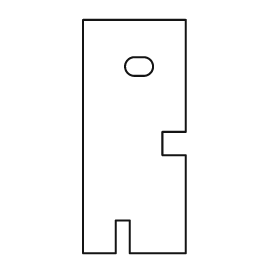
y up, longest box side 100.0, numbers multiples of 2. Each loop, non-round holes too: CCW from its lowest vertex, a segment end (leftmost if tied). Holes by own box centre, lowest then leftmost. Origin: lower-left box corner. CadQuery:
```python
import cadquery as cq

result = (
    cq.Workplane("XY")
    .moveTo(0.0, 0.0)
    .lineTo(14.0, 0.0)
    .lineTo(14.0, 14.0)
    .lineTo(20.0, 14.0)
    .lineTo(20.0, 0.0)
    .lineTo(44.0, 0.0)
    .lineTo(44.0, 42.0)
    .lineTo(34.0, 42.0)
    .lineTo(34.0, 52.0)
    .lineTo(44.0, 52.0)
    .lineTo(44.0, 100.0)
    .lineTo(0.0, 100.0)
    .close()
    .moveTo(22.0, 76.0)
    .lineTo(26.0, 76.0)
    .threePointArc((30.0, 80.0), (26.0, 84.0))
    .lineTo(22.0, 84.0)
    .threePointArc((18.0, 80.0), (22.0, 76.0))
    .close()
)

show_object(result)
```